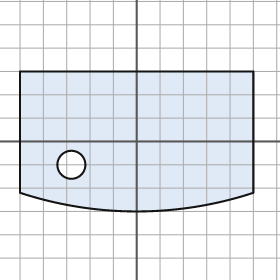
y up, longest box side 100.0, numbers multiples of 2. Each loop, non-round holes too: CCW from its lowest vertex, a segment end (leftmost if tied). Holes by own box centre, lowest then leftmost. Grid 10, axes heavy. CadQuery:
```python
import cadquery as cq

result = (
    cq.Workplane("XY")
    .moveTo(-50.0, -22.0)
    .threePointArc((0.0, -30.0), (50.0, -22.0))
    .lineTo(50.0, 30.0)
    .lineTo(-50.0, 30.0)
    .close()
    .moveTo(-28.0, -10.0)
    .circle(6.0)
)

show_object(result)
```